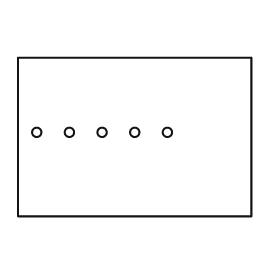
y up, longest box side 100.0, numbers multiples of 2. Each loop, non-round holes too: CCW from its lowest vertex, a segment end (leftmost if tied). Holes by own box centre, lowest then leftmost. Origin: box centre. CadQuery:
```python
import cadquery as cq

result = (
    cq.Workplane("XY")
    .moveTo(-50.0, -34.0)
    .lineTo(50.0, -34.0)
    .lineTo(50.0, 34.0)
    .lineTo(-50.0, 34.0)
    .close()
    .moveTo(-42.0, 2.0)
    .circle(2.0)
    .moveTo(-28.0, 2.0)
    .circle(2.0)
    .moveTo(-14.0, 2.0)
    .circle(2.0)
    .moveTo(0.0, 2.0)
    .circle(2.0)
    .moveTo(14.0, 2.0)
    .circle(2.0)
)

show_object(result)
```